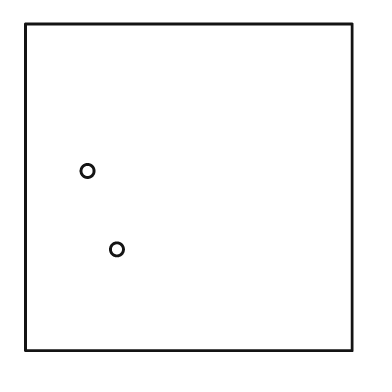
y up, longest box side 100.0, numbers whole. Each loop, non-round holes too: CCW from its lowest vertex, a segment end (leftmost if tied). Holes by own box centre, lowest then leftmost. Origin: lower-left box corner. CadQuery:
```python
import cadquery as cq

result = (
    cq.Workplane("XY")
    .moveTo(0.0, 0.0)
    .lineTo(100.0, 0.0)
    .lineTo(100.0, 100.0)
    .lineTo(0.0, 100.0)
    .close()
    .moveTo(28.0, 31.0)
    .circle(2.0)
    .moveTo(19.0, 55.0)
    .circle(2.0)
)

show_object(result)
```